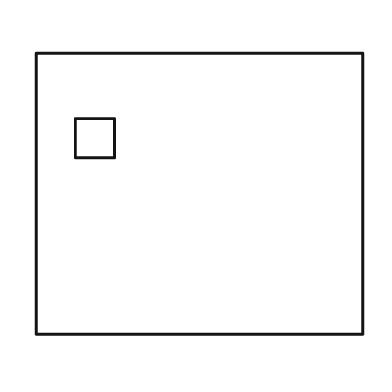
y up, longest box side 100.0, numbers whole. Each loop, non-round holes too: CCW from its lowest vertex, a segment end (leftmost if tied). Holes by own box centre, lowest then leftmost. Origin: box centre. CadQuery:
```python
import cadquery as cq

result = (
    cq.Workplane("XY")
    .moveTo(-50.0, -43.0)
    .lineTo(50.0, -43.0)
    .lineTo(50.0, 43.0)
    .lineTo(-50.0, 43.0)
    .close()
    .moveTo(-38.0, 11.0)
    .lineTo(-26.0, 11.0)
    .lineTo(-26.0, 23.0)
    .lineTo(-38.0, 23.0)
    .close()
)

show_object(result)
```